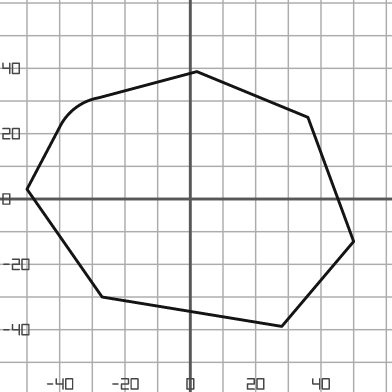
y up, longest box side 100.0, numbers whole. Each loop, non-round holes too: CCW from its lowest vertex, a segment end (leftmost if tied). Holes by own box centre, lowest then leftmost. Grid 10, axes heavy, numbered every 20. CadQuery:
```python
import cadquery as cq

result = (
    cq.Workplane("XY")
    .moveTo(28.0, -39.0)
    .lineTo(50.0, -13.0)
    .lineTo(36.0, 25.0)
    .lineTo(2.0, 39.0)
    .lineTo(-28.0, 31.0)
    .threePointArc((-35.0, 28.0), (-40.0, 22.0))
    .lineTo(-50.0, 3.0)
    .lineTo(-27.0, -30.0)
    .close()
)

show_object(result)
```